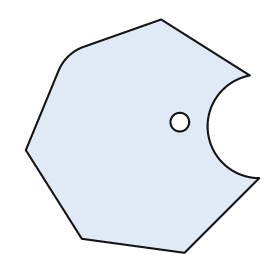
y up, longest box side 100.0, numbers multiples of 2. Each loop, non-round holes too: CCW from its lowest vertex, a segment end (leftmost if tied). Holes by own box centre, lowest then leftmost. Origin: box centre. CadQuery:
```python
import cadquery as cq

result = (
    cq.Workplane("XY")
    .moveTo(18.0, -50.0)
    .lineTo(50.0, -18.0)
    .threePointArc((28.0, 2.0), (46.0, 26.0))
    .lineTo(8.0, 50.0)
    .lineTo(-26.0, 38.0)
    .threePointArc((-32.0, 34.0), (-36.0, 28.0))
    .lineTo(-50.0, -6.0)
    .lineTo(-26.0, -44.0)
    .close()
    .moveTo(16.0, 6.0)
    .circle(4.0)
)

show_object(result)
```